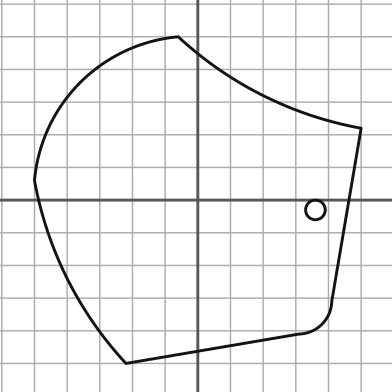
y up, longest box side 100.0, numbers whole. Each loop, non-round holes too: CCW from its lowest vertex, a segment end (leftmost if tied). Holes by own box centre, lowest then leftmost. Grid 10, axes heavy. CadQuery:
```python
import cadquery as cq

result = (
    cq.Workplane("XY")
    .moveTo(-22.0, -50.0)
    .lineTo(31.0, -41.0)
    .threePointArc((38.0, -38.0), (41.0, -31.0))
    .lineTo(50.0, 22.0)
    .threePointArc((20.0, 32.0), (-6.0, 50.0))
    .threePointArc((-36.0, 36.0), (-50.0, 6.0))
    .threePointArc((-40.0, -24.0), (-22.0, -50.0))
    .close()
    .moveTo(36.0, -3.0)
    .circle(3.0)
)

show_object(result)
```